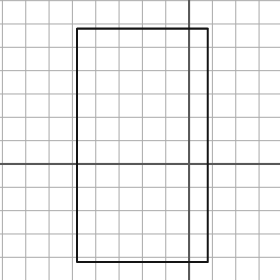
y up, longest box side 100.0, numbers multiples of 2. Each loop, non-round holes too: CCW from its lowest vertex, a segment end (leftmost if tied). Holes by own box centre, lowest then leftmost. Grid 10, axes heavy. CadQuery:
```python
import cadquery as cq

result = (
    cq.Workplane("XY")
    .moveTo(-48.0, -42.0)
    .lineTo(8.0, -42.0)
    .lineTo(8.0, 58.0)
    .lineTo(-48.0, 58.0)
    .close()
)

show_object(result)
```